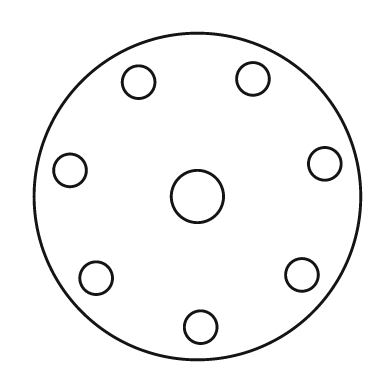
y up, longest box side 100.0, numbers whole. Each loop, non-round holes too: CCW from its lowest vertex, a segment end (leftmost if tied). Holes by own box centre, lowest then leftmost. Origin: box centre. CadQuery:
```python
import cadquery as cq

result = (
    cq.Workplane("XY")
    .moveTo(0.0, 0.0)
    .circle(50.0)
    .moveTo(1.0, -40.0)
    .circle(5.0)
    .moveTo(-31.0, -25.0)
    .circle(5.0)
    .moveTo(32.0, -24.0)
    .circle(5.0)
    .moveTo(0.0, 0.0)
    .circle(8.0)
    .moveTo(-39.0, 8.0)
    .circle(5.0)
    .moveTo(39.0, 10.0)
    .circle(5.0)
    .moveTo(-18.0, 35.0)
    .circle(5.0)
    .moveTo(17.0, 36.0)
    .circle(5.0)
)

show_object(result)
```